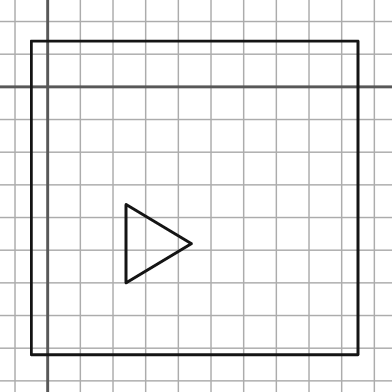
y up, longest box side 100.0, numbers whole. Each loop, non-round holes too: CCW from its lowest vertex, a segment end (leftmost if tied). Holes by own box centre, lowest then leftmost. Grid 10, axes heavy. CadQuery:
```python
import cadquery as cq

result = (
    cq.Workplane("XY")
    .moveTo(-5.0, -82.0)
    .lineTo(95.0, -82.0)
    .lineTo(95.0, 14.0)
    .lineTo(-5.0, 14.0)
    .close()
    .moveTo(24.0, -60.0)
    .lineTo(44.0, -48.0)
    .lineTo(24.0, -36.0)
    .close()
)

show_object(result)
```